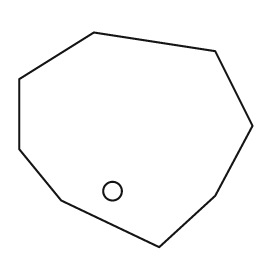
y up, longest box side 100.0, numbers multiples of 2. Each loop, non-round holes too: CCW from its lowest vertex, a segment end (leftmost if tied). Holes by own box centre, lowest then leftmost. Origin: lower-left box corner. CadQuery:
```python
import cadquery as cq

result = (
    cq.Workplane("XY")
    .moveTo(60.0, 0.0)
    .lineTo(84.0, 22.0)
    .lineTo(100.0, 52.0)
    .lineTo(84.0, 84.0)
    .lineTo(32.0, 92.0)
    .lineTo(0.0, 72.0)
    .lineTo(0.0, 42.0)
    .lineTo(18.0, 20.0)
    .close()
    .moveTo(40.0, 24.0)
    .circle(4.0)
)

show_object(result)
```